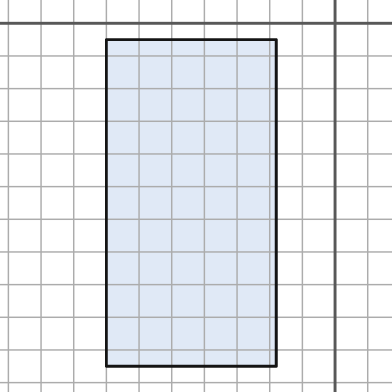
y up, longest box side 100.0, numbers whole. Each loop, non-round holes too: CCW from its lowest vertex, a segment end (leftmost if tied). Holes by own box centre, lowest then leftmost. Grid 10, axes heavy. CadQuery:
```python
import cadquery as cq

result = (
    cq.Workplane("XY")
    .moveTo(-70.0, -105.0)
    .lineTo(-18.0, -105.0)
    .lineTo(-18.0, -5.0)
    .lineTo(-70.0, -5.0)
    .close()
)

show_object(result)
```